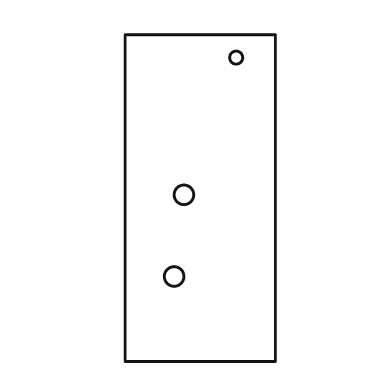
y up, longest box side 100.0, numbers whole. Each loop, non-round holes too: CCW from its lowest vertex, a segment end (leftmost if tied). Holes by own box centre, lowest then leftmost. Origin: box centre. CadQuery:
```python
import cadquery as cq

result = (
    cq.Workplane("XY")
    .moveTo(-23.0, -50.0)
    .lineTo(23.0, -50.0)
    .lineTo(23.0, 50.0)
    .lineTo(-23.0, 50.0)
    .close()
    .moveTo(-8.0, -24.0)
    .circle(3.0)
    .moveTo(-5.0, 1.0)
    .circle(3.0)
    .moveTo(11.0, 43.0)
    .circle(2.0)
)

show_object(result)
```